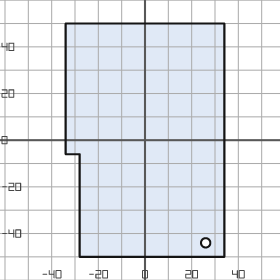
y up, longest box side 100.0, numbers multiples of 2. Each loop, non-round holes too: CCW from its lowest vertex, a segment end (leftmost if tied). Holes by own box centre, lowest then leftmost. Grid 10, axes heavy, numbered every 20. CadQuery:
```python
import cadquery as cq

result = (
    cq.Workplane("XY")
    .moveTo(-28.0, -50.0)
    .lineTo(34.0, -50.0)
    .lineTo(34.0, 50.0)
    .lineTo(-34.0, 50.0)
    .lineTo(-34.0, -6.0)
    .lineTo(-28.0, -6.0)
    .close()
    .moveTo(26.0, -44.0)
    .circle(2.0)
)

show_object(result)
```